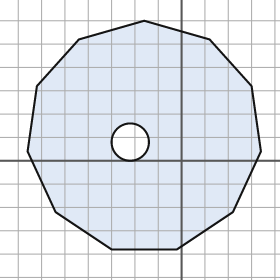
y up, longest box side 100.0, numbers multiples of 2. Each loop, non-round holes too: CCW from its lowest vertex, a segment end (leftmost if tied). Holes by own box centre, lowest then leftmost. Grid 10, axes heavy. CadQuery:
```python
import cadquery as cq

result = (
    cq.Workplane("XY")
    .moveTo(-30.0, -38.0)
    .lineTo(-2.0, -38.0)
    .lineTo(22.0, -22.0)
    .lineTo(34.0, 4.0)
    .lineTo(30.0, 32.0)
    .lineTo(12.0, 52.0)
    .lineTo(-16.0, 60.0)
    .lineTo(-44.0, 52.0)
    .lineTo(-62.0, 32.0)
    .lineTo(-66.0, 4.0)
    .lineTo(-54.0, -22.0)
    .close()
    .moveTo(-22.0, 8.0)
    .circle(8.0)
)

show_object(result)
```